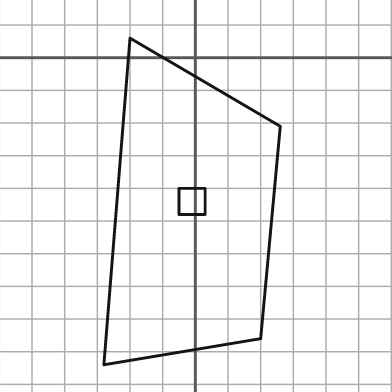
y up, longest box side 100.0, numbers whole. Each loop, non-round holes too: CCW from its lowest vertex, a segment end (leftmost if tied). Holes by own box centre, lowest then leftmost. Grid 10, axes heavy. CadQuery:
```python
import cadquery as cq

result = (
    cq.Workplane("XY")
    .moveTo(-28.0, -94.0)
    .lineTo(20.0, -86.0)
    .lineTo(26.0, -21.0)
    .lineTo(-20.0, 6.0)
    .close()
    .moveTo(-5.0, -48.0)
    .lineTo(3.0, -48.0)
    .lineTo(3.0, -40.0)
    .lineTo(-5.0, -40.0)
    .close()
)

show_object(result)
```